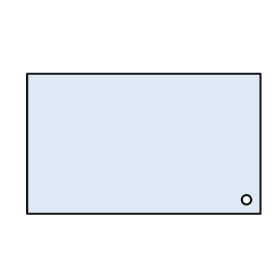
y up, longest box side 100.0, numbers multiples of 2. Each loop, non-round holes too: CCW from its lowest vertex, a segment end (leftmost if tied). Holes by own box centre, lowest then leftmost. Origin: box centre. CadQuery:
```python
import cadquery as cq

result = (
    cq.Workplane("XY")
    .moveTo(-50.0, -30.0)
    .lineTo(50.0, -30.0)
    .lineTo(50.0, 30.0)
    .lineTo(-50.0, 30.0)
    .close()
    .moveTo(44.0, -24.0)
    .circle(2.0)
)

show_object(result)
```